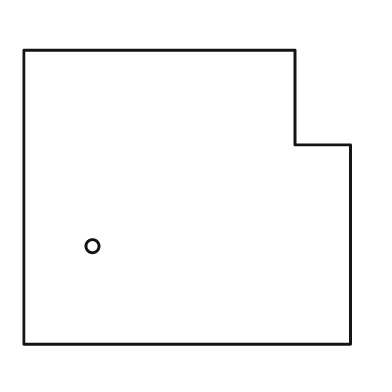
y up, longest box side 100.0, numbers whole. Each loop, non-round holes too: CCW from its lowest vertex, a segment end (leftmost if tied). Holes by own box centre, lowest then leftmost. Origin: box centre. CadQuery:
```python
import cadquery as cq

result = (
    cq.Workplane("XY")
    .moveTo(-50.0, -45.0)
    .lineTo(50.0, -45.0)
    .lineTo(50.0, 16.0)
    .lineTo(33.0, 16.0)
    .lineTo(33.0, 45.0)
    .lineTo(-50.0, 45.0)
    .close()
    .moveTo(-29.0, -15.0)
    .circle(2.0)
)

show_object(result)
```